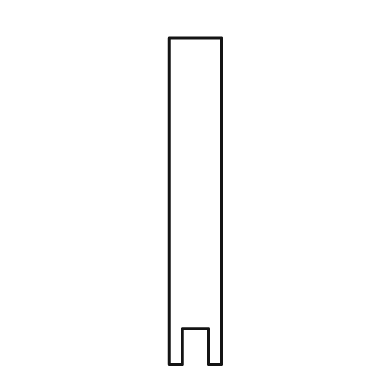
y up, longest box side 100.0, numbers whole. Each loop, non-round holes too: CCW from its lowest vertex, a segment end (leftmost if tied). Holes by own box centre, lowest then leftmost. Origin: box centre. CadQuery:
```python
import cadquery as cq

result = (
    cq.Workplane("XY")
    .moveTo(-8.0, -50.0)
    .lineTo(-4.0, -50.0)
    .lineTo(-4.0, -39.0)
    .lineTo(4.0, -39.0)
    .lineTo(4.0, -50.0)
    .lineTo(8.0, -50.0)
    .lineTo(8.0, 50.0)
    .lineTo(-8.0, 50.0)
    .close()
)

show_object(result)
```